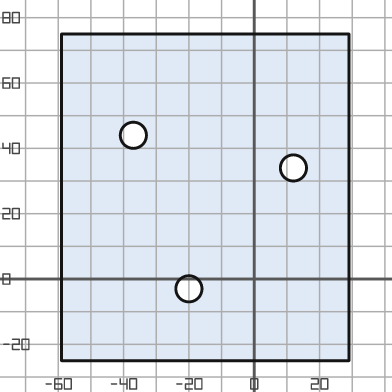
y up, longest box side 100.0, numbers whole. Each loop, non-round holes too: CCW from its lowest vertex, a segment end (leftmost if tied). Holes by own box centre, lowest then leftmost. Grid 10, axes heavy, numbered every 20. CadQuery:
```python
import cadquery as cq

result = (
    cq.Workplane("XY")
    .moveTo(-59.0, -25.0)
    .lineTo(29.0, -25.0)
    .lineTo(29.0, 75.0)
    .lineTo(-59.0, 75.0)
    .close()
    .moveTo(-20.0, -3.0)
    .circle(4.0)
    .moveTo(12.0, 34.0)
    .circle(4.0)
    .moveTo(-37.0, 44.0)
    .circle(4.0)
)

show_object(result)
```